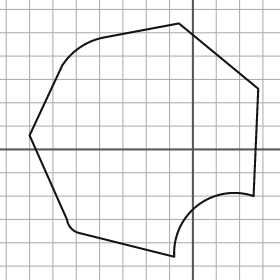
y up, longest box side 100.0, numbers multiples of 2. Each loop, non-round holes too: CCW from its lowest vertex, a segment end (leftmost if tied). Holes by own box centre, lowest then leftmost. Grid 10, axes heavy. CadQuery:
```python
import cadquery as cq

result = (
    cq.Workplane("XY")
    .moveTo(-8.0, -46.0)
    .threePointArc((2.0, -24.0), (26.0, -20.0))
    .lineTo(28.0, 26.0)
    .lineTo(-6.0, 54.0)
    .lineTo(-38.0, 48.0)
    .threePointArc((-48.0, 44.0), (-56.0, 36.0))
    .lineTo(-70.0, 6.0)
    .lineTo(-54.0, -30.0)
    .threePointArc((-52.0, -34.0), (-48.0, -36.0))
    .close()
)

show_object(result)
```